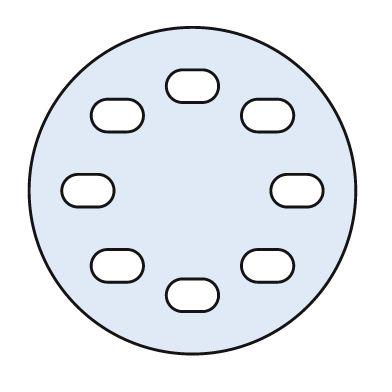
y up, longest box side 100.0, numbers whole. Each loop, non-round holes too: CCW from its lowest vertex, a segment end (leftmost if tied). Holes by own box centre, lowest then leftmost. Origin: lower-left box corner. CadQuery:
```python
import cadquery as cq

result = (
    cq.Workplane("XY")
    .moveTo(50.0, 50.0)
    .circle(50.0)
    .moveTo(47.0, 13.0)
    .lineTo(53.0, 13.0)
    .threePointArc((58.0, 18.0), (53.0, 23.0))
    .lineTo(47.0, 23.0)
    .threePointArc((42.0, 18.0), (47.0, 13.0))
    .close()
    .moveTo(24.0, 22.0)
    .lineTo(30.0, 22.0)
    .threePointArc((35.0, 27.0), (30.0, 32.0))
    .lineTo(24.0, 32.0)
    .threePointArc((19.0, 27.0), (24.0, 22.0))
    .close()
    .moveTo(70.0, 22.0)
    .lineTo(76.0, 22.0)
    .threePointArc((81.0, 27.0), (76.0, 32.0))
    .lineTo(70.0, 32.0)
    .threePointArc((65.0, 27.0), (70.0, 22.0))
    .close()
    .moveTo(15.0, 45.0)
    .lineTo(21.0, 45.0)
    .threePointArc((26.0, 50.0), (21.0, 55.0))
    .lineTo(15.0, 55.0)
    .threePointArc((10.0, 50.0), (15.0, 45.0))
    .close()
    .moveTo(79.0, 45.0)
    .lineTo(85.0, 45.0)
    .threePointArc((90.0, 50.0), (85.0, 55.0))
    .lineTo(79.0, 55.0)
    .threePointArc((74.0, 50.0), (79.0, 45.0))
    .close()
    .moveTo(24.0, 68.0)
    .lineTo(30.0, 68.0)
    .threePointArc((35.0, 73.0), (30.0, 78.0))
    .lineTo(24.0, 78.0)
    .threePointArc((19.0, 73.0), (24.0, 68.0))
    .close()
    .moveTo(70.0, 68.0)
    .lineTo(76.0, 68.0)
    .threePointArc((81.0, 73.0), (76.0, 78.0))
    .lineTo(70.0, 78.0)
    .threePointArc((65.0, 73.0), (70.0, 68.0))
    .close()
    .moveTo(47.0, 77.0)
    .lineTo(53.0, 77.0)
    .threePointArc((58.0, 82.0), (53.0, 87.0))
    .lineTo(47.0, 87.0)
    .threePointArc((42.0, 82.0), (47.0, 77.0))
    .close()
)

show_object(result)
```